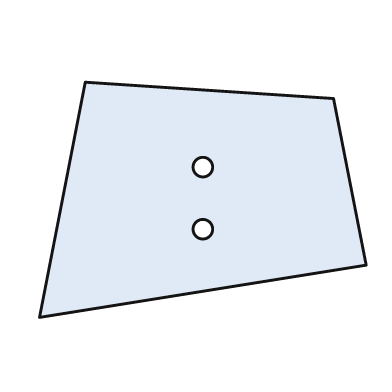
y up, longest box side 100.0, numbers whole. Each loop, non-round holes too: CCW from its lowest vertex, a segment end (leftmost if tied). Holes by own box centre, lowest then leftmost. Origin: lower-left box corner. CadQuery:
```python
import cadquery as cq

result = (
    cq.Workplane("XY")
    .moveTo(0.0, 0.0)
    .lineTo(100.0, 16.0)
    .lineTo(90.0, 67.0)
    .lineTo(14.0, 72.0)
    .close()
    .moveTo(50.0, 27.0)
    .circle(3.0)
    .moveTo(50.0, 46.0)
    .circle(3.0)
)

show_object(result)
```